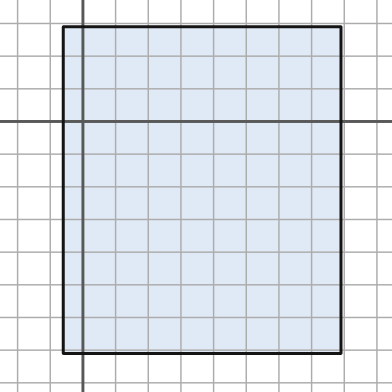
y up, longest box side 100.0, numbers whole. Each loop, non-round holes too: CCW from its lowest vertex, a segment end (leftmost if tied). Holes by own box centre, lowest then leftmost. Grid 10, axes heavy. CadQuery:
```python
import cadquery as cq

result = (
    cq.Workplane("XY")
    .moveTo(-6.0, -71.0)
    .lineTo(79.0, -71.0)
    .lineTo(79.0, 29.0)
    .lineTo(-6.0, 29.0)
    .close()
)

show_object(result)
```